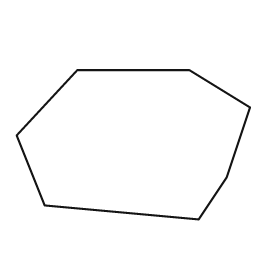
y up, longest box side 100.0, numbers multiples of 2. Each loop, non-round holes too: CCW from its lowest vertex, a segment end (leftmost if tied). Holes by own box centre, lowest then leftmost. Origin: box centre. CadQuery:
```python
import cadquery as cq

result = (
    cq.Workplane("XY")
    .moveTo(28.0, -32.0)
    .lineTo(40.0, -14.0)
    .lineTo(50.0, 16.0)
    .lineTo(24.0, 32.0)
    .lineTo(-24.0, 32.0)
    .lineTo(-50.0, 4.0)
    .lineTo(-38.0, -26.0)
    .close()
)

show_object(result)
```